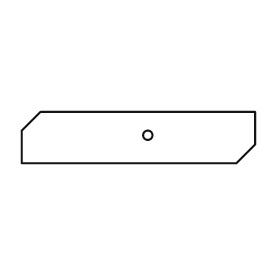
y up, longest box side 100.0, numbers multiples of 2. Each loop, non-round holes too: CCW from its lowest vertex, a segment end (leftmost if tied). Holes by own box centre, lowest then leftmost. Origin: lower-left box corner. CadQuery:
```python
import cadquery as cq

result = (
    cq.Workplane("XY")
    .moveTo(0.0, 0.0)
    .lineTo(92.0, 0.0)
    .lineTo(100.0, 8.0)
    .lineTo(100.0, 22.0)
    .lineTo(8.0, 22.0)
    .lineTo(0.0, 14.0)
    .close()
    .moveTo(54.0, 12.0)
    .circle(2.0)
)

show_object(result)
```